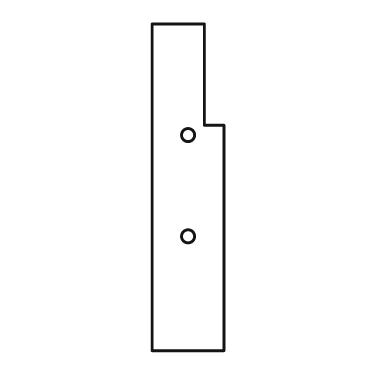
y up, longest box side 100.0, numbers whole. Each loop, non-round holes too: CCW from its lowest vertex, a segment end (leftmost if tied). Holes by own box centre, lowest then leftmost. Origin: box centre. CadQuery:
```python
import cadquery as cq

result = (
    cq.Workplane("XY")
    .moveTo(-11.0, -50.0)
    .lineTo(11.0, -50.0)
    .lineTo(11.0, 19.0)
    .lineTo(5.0, 19.0)
    .lineTo(5.0, 50.0)
    .lineTo(-11.0, 50.0)
    .close()
    .moveTo(0.0, -15.0)
    .circle(2.0)
    .moveTo(0.0, 16.0)
    .circle(2.0)
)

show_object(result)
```